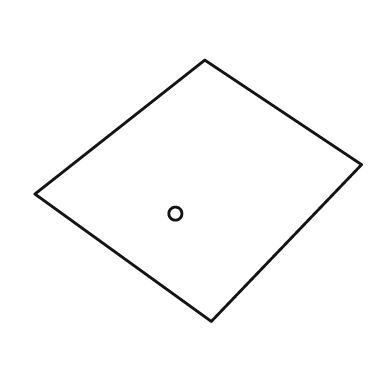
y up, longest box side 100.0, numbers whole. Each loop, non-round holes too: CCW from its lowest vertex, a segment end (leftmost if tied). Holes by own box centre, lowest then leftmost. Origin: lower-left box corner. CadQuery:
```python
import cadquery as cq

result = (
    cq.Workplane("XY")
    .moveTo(54.0, 0.0)
    .lineTo(100.0, 48.0)
    .lineTo(52.0, 80.0)
    .lineTo(0.0, 39.0)
    .close()
    .moveTo(43.0, 33.0)
    .circle(2.0)
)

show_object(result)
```